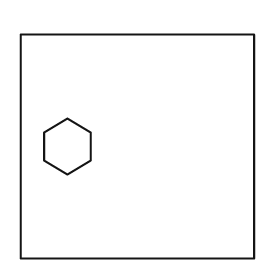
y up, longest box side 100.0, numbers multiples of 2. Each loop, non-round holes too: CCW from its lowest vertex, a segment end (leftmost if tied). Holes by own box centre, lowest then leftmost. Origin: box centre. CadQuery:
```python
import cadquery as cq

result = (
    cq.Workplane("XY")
    .moveTo(-50.0, -48.0)
    .lineTo(50.0, -48.0)
    .lineTo(50.0, 48.0)
    .lineTo(-50.0, 48.0)
    .close()
    .moveTo(-30.0, -12.0)
    .lineTo(-20.0, -6.0)
    .lineTo(-20.0, 6.0)
    .lineTo(-30.0, 12.0)
    .lineTo(-40.0, 6.0)
    .lineTo(-40.0, -6.0)
    .close()
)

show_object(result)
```